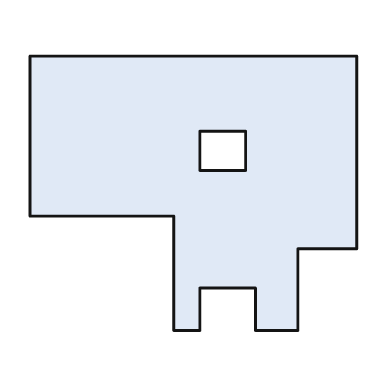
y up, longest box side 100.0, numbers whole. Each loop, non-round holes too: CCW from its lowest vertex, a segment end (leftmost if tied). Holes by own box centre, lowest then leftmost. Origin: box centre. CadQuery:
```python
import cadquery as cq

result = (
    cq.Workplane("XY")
    .moveTo(-6.0, -42.0)
    .lineTo(2.0, -42.0)
    .lineTo(2.0, -29.0)
    .lineTo(19.0, -29.0)
    .lineTo(19.0, -42.0)
    .lineTo(32.0, -42.0)
    .lineTo(32.0, -17.0)
    .lineTo(50.0, -17.0)
    .lineTo(50.0, 42.0)
    .lineTo(-50.0, 42.0)
    .lineTo(-50.0, -7.0)
    .lineTo(-6.0, -7.0)
    .close()
    .moveTo(2.0, 7.0)
    .lineTo(16.0, 7.0)
    .lineTo(16.0, 19.0)
    .lineTo(2.0, 19.0)
    .close()
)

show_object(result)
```